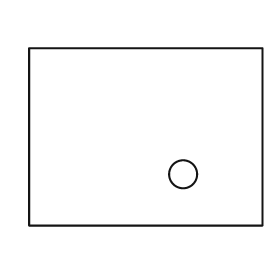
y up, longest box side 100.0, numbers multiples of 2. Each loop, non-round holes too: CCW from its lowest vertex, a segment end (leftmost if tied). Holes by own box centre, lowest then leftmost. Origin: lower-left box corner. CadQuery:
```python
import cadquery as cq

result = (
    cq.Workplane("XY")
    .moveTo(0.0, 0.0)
    .lineTo(100.0, 0.0)
    .lineTo(100.0, 76.0)
    .lineTo(0.0, 76.0)
    .close()
    .moveTo(66.0, 22.0)
    .circle(6.0)
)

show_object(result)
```